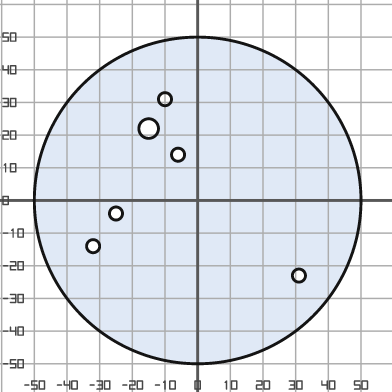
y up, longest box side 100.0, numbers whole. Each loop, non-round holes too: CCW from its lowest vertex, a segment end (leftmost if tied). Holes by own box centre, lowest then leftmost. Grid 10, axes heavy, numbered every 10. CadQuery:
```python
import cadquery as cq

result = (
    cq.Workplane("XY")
    .moveTo(0.0, 0.0)
    .circle(50.0)
    .moveTo(31.0, -23.0)
    .circle(2.0)
    .moveTo(-32.0, -14.0)
    .circle(2.0)
    .moveTo(-25.0, -4.0)
    .circle(2.0)
    .moveTo(-6.0, 14.0)
    .circle(2.0)
    .moveTo(-15.0, 22.0)
    .circle(3.0)
    .moveTo(-10.0, 31.0)
    .circle(2.0)
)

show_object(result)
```